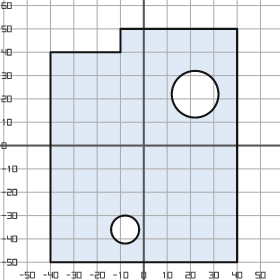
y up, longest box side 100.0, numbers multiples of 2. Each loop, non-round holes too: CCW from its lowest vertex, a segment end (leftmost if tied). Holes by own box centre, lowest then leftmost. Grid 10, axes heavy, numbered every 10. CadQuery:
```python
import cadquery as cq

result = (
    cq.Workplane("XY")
    .moveTo(-40.0, -50.0)
    .lineTo(40.0, -50.0)
    .lineTo(40.0, 50.0)
    .lineTo(-10.0, 50.0)
    .lineTo(-10.0, 40.0)
    .lineTo(-40.0, 40.0)
    .close()
    .moveTo(-8.0, -36.0)
    .circle(6.0)
    .moveTo(22.0, 22.0)
    .circle(10.0)
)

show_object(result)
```